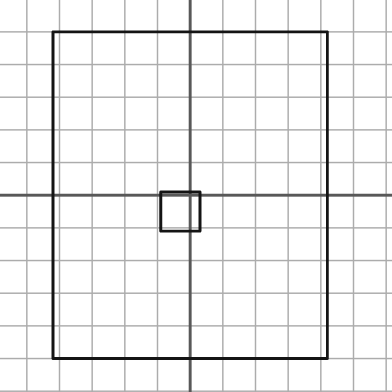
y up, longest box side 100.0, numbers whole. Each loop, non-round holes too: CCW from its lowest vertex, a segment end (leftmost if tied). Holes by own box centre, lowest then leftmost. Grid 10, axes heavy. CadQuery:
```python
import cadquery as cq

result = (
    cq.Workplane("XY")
    .moveTo(-42.0, -50.0)
    .lineTo(42.0, -50.0)
    .lineTo(42.0, 50.0)
    .lineTo(-42.0, 50.0)
    .close()
    .moveTo(-9.0, -11.0)
    .lineTo(3.0, -11.0)
    .lineTo(3.0, 1.0)
    .lineTo(-9.0, 1.0)
    .close()
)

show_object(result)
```